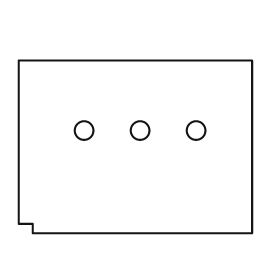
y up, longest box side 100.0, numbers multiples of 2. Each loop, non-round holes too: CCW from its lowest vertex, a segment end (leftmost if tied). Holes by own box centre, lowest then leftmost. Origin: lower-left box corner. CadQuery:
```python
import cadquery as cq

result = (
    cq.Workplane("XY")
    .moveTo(6.0, 0.0)
    .lineTo(100.0, 0.0)
    .lineTo(100.0, 74.0)
    .lineTo(0.0, 74.0)
    .lineTo(0.0, 4.0)
    .lineTo(6.0, 4.0)
    .close()
    .moveTo(28.0, 44.0)
    .circle(4.0)
    .moveTo(52.0, 44.0)
    .circle(4.0)
    .moveTo(76.0, 44.0)
    .circle(4.0)
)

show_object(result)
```